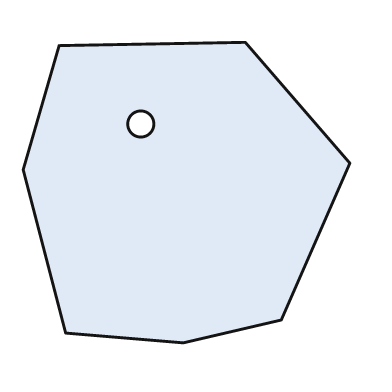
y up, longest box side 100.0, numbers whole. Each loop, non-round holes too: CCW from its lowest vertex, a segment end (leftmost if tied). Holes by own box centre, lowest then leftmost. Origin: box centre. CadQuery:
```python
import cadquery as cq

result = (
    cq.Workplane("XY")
    .moveTo(-1.0, -46.0)
    .lineTo(29.0, -39.0)
    .lineTo(50.0, 9.0)
    .lineTo(18.0, 46.0)
    .lineTo(-39.0, 45.0)
    .lineTo(-50.0, 7.0)
    .lineTo(-37.0, -43.0)
    .close()
    .moveTo(-14.0, 21.0)
    .circle(4.0)
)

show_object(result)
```